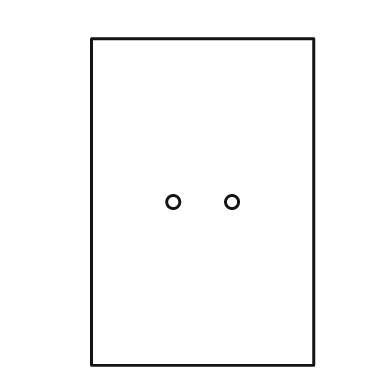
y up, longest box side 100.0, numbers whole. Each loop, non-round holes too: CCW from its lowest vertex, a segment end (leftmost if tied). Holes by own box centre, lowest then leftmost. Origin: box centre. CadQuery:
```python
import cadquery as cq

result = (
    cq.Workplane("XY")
    .moveTo(-34.0, -50.0)
    .lineTo(34.0, -50.0)
    .lineTo(34.0, 50.0)
    .lineTo(-34.0, 50.0)
    .close()
    .moveTo(-9.0, 0.0)
    .circle(2.0)
    .moveTo(9.0, 0.0)
    .circle(2.0)
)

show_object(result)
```